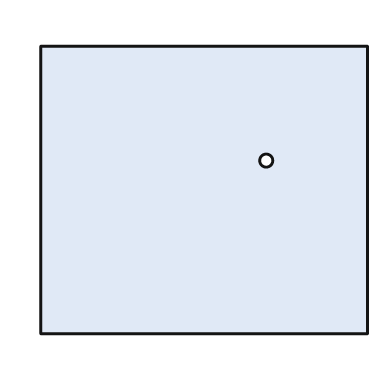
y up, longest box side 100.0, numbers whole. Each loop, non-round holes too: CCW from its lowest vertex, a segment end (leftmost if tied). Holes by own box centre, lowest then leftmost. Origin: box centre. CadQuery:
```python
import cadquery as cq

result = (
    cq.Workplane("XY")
    .moveTo(-50.0, -44.0)
    .lineTo(50.0, -44.0)
    .lineTo(50.0, 44.0)
    .lineTo(-50.0, 44.0)
    .close()
    .moveTo(19.0, 9.0)
    .circle(2.0)
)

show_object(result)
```